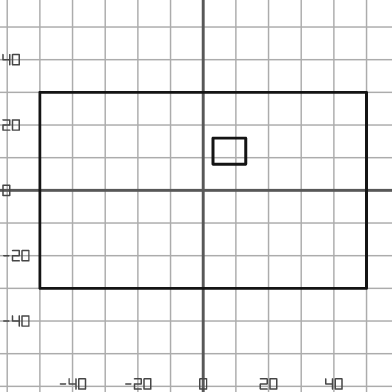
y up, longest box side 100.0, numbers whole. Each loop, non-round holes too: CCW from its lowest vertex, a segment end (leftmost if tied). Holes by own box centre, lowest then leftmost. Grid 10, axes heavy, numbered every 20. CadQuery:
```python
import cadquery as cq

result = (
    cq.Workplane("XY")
    .moveTo(-50.0, -30.0)
    .lineTo(50.0, -30.0)
    .lineTo(50.0, 30.0)
    .lineTo(-50.0, 30.0)
    .close()
    .moveTo(3.0, 8.0)
    .lineTo(13.0, 8.0)
    .lineTo(13.0, 16.0)
    .lineTo(3.0, 16.0)
    .close()
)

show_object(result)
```